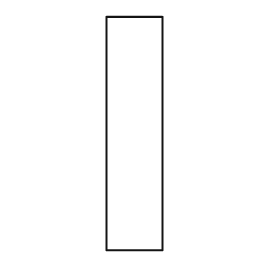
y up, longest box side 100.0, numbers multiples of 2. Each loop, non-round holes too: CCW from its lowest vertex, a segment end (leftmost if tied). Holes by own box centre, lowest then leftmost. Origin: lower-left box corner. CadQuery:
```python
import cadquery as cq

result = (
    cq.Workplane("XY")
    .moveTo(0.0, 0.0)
    .lineTo(24.0, 0.0)
    .lineTo(24.0, 100.0)
    .lineTo(0.0, 100.0)
    .close()
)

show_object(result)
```